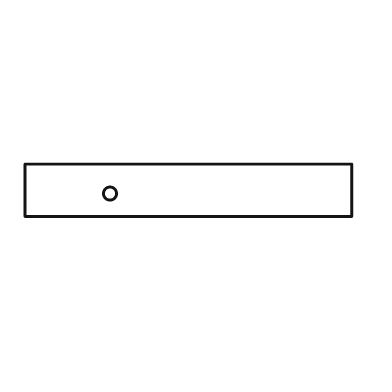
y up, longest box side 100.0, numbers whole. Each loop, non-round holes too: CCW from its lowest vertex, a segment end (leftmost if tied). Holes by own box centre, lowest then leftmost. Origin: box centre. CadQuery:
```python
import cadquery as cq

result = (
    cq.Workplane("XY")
    .moveTo(-50.0, -8.0)
    .lineTo(50.0, -8.0)
    .lineTo(50.0, 8.0)
    .lineTo(-50.0, 8.0)
    .close()
    .moveTo(-24.0, -1.0)
    .circle(2.0)
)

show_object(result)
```